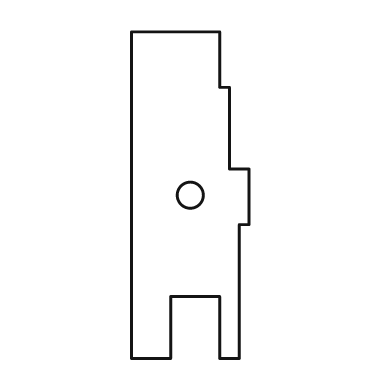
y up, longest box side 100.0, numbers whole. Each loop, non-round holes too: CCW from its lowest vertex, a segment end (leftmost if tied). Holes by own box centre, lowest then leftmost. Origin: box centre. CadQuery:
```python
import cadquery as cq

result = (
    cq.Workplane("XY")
    .moveTo(-18.0, -50.0)
    .lineTo(-6.0, -50.0)
    .lineTo(-6.0, -31.0)
    .lineTo(9.0, -31.0)
    .lineTo(9.0, -50.0)
    .lineTo(15.0, -50.0)
    .lineTo(15.0, -9.0)
    .lineTo(18.0, -9.0)
    .lineTo(18.0, 8.0)
    .lineTo(12.0, 8.0)
    .lineTo(12.0, 33.0)
    .lineTo(9.0, 33.0)
    .lineTo(9.0, 50.0)
    .lineTo(-18.0, 50.0)
    .close()
    .moveTo(0.0, 0.0)
    .circle(4.0)
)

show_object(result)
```